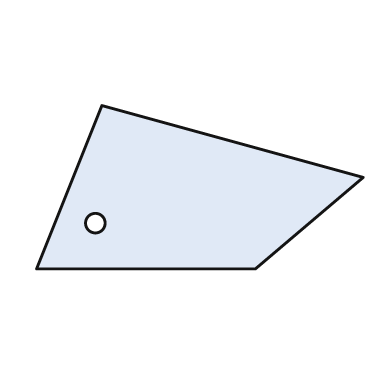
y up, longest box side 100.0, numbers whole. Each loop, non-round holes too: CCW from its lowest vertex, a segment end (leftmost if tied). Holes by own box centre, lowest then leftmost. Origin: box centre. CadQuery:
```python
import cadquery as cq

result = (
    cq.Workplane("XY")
    .moveTo(-50.0, -25.0)
    .lineTo(17.0, -25.0)
    .lineTo(50.0, 3.0)
    .lineTo(-30.0, 25.0)
    .close()
    .moveTo(-32.0, -11.0)
    .circle(3.0)
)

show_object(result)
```